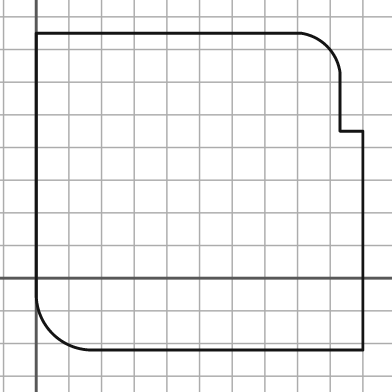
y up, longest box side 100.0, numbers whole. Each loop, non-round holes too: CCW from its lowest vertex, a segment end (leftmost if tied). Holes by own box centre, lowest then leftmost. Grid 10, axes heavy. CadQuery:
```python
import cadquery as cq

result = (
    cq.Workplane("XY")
    .moveTo(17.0, -22.0)
    .lineTo(100.0, -22.0)
    .lineTo(100.0, 45.0)
    .lineTo(93.0, 45.0)
    .lineTo(93.0, 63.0)
    .threePointArc((89.0, 71.0), (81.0, 75.0))
    .lineTo(0.0, 75.0)
    .lineTo(0.0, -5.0)
    .threePointArc((5.0, -17.0), (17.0, -22.0))
    .close()
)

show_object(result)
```